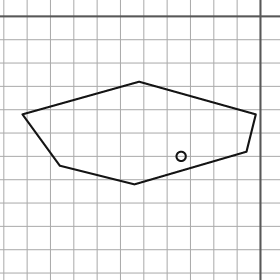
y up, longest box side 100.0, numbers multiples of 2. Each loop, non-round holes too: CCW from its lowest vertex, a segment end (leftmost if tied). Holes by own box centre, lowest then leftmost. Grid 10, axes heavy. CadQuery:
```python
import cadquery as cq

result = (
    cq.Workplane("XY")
    .moveTo(-54.0, -72.0)
    .lineTo(-6.0, -58.0)
    .lineTo(-2.0, -42.0)
    .lineTo(-52.0, -28.0)
    .lineTo(-102.0, -42.0)
    .lineTo(-86.0, -64.0)
    .close()
    .moveTo(-34.0, -60.0)
    .circle(2.0)
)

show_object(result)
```